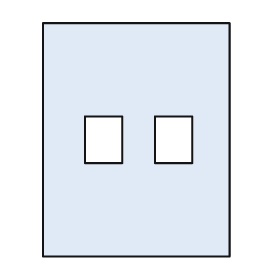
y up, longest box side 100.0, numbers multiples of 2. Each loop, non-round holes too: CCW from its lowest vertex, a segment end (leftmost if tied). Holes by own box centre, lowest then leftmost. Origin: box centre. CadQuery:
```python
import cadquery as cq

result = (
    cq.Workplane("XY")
    .moveTo(-40.0, -50.0)
    .lineTo(40.0, -50.0)
    .lineTo(40.0, 50.0)
    .lineTo(-40.0, 50.0)
    .close()
    .moveTo(-22.0, -10.0)
    .lineTo(-6.0, -10.0)
    .lineTo(-6.0, 10.0)
    .lineTo(-22.0, 10.0)
    .close()
    .moveTo(8.0, -10.0)
    .lineTo(24.0, -10.0)
    .lineTo(24.0, 10.0)
    .lineTo(8.0, 10.0)
    .close()
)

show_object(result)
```